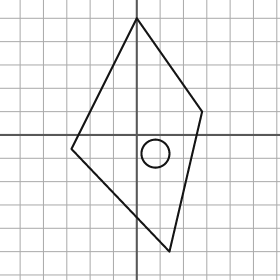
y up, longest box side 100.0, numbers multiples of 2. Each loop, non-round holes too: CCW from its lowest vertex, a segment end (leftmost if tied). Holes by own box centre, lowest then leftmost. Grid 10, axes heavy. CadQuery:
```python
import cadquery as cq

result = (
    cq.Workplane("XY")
    .moveTo(14.0, -50.0)
    .lineTo(28.0, 10.0)
    .lineTo(0.0, 50.0)
    .lineTo(-28.0, -6.0)
    .close()
    .moveTo(8.0, -8.0)
    .circle(6.0)
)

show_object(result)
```